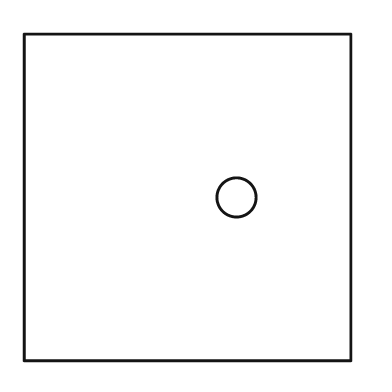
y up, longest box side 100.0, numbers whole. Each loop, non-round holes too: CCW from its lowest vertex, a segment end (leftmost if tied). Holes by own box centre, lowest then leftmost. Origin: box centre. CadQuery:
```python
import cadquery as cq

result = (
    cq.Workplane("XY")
    .moveTo(-50.0, -50.0)
    .lineTo(50.0, -50.0)
    .lineTo(50.0, 50.0)
    .lineTo(-50.0, 50.0)
    .close()
    .moveTo(15.0, 0.0)
    .circle(6.0)
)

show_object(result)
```